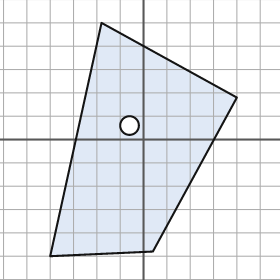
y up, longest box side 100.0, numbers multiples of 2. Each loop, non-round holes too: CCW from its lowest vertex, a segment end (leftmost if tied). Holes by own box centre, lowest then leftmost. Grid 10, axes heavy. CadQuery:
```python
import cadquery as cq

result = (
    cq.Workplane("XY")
    .moveTo(-40.0, -50.0)
    .lineTo(4.0, -48.0)
    .lineTo(40.0, 18.0)
    .lineTo(-18.0, 50.0)
    .close()
    .moveTo(-6.0, 6.0)
    .circle(4.0)
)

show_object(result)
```